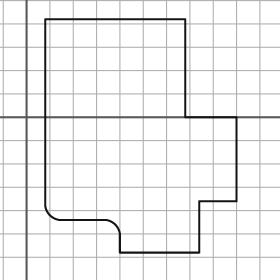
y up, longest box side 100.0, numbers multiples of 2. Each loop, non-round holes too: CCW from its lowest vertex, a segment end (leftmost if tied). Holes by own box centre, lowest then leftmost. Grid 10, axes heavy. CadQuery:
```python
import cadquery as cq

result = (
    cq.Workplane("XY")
    .moveTo(40.0, -58.0)
    .lineTo(74.0, -58.0)
    .lineTo(74.0, -36.0)
    .lineTo(90.0, -36.0)
    .lineTo(90.0, 0.0)
    .lineTo(68.0, 0.0)
    .lineTo(68.0, 42.0)
    .lineTo(8.0, 42.0)
    .lineTo(8.0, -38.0)
    .threePointArc((10.0, -42.0), (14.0, -44.0))
    .lineTo(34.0, -44.0)
    .threePointArc((38.0, -46.0), (40.0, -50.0))
    .close()
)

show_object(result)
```